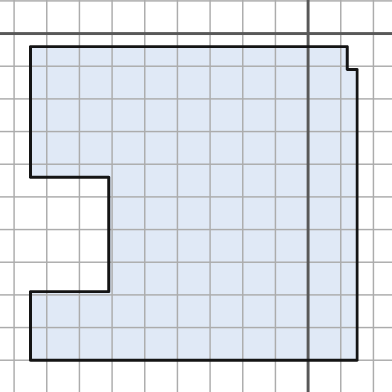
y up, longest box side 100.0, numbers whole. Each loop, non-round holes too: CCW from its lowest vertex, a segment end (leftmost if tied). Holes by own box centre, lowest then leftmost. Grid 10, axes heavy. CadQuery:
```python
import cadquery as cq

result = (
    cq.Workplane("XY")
    .moveTo(-85.0, -100.0)
    .lineTo(15.0, -100.0)
    .lineTo(15.0, -11.0)
    .lineTo(12.0, -11.0)
    .lineTo(12.0, -4.0)
    .lineTo(-85.0, -4.0)
    .lineTo(-85.0, -44.0)
    .lineTo(-61.0, -44.0)
    .lineTo(-61.0, -79.0)
    .lineTo(-85.0, -79.0)
    .close()
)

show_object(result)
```